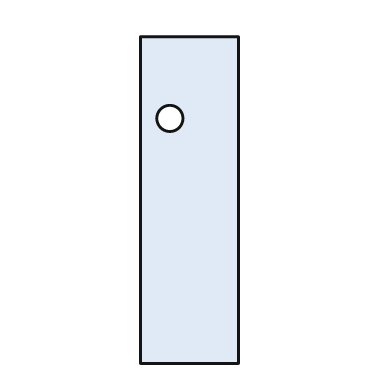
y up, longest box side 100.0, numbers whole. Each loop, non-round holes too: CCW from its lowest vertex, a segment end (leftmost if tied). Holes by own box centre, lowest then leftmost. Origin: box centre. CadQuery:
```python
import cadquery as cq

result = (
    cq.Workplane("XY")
    .moveTo(-15.0, -50.0)
    .lineTo(15.0, -50.0)
    .lineTo(15.0, 50.0)
    .lineTo(-15.0, 50.0)
    .close()
    .moveTo(-6.0, 25.0)
    .circle(4.0)
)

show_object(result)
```